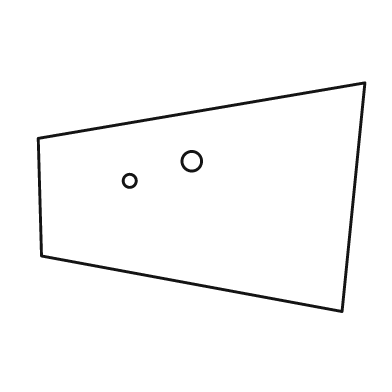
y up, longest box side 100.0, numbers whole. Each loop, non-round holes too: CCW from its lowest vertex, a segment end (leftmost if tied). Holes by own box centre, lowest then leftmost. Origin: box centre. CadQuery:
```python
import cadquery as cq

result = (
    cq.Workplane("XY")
    .moveTo(43.0, -35.0)
    .lineTo(50.0, 35.0)
    .lineTo(-50.0, 18.0)
    .lineTo(-49.0, -18.0)
    .close()
    .moveTo(-22.0, 5.0)
    .circle(2.0)
    .moveTo(-3.0, 11.0)
    .circle(3.0)
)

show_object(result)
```